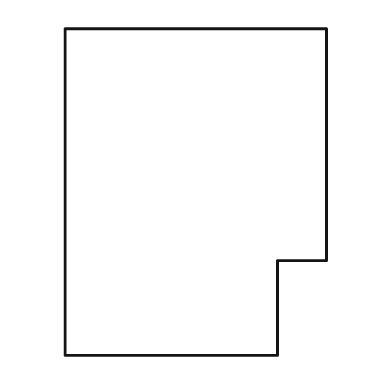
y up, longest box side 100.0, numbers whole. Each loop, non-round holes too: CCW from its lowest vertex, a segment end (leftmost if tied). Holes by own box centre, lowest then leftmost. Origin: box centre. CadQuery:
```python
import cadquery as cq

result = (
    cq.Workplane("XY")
    .moveTo(-40.0, -50.0)
    .lineTo(25.0, -50.0)
    .lineTo(25.0, -21.0)
    .lineTo(40.0, -21.0)
    .lineTo(40.0, 50.0)
    .lineTo(-40.0, 50.0)
    .close()
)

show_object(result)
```